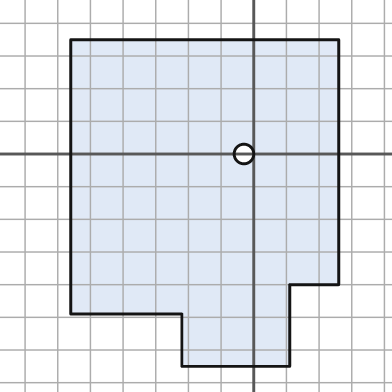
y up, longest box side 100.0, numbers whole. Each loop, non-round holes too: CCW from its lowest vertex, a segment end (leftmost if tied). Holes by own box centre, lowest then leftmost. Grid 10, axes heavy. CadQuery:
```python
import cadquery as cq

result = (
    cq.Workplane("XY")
    .moveTo(-22.0, -65.0)
    .lineTo(11.0, -65.0)
    .lineTo(11.0, -40.0)
    .lineTo(26.0, -40.0)
    .lineTo(26.0, 35.0)
    .lineTo(-56.0, 35.0)
    .lineTo(-56.0, -49.0)
    .lineTo(-22.0, -49.0)
    .close()
    .moveTo(-3.0, 0.0)
    .circle(3.0)
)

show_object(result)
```